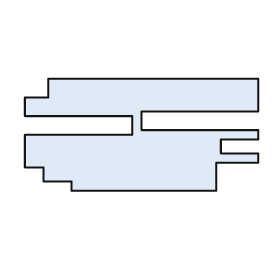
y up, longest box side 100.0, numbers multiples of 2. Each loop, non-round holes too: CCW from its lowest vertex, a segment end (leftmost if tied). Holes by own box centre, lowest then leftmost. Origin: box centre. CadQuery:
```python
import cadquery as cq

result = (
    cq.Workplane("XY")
    .moveTo(-30.0, -24.0)
    .lineTo(32.0, -24.0)
    .lineTo(32.0, -12.0)
    .lineTo(50.0, -12.0)
    .lineTo(50.0, -8.0)
    .lineTo(34.0, -8.0)
    .lineTo(34.0, -2.0)
    .lineTo(50.0, -2.0)
    .lineTo(50.0, 2.0)
    .lineTo(0.0, 2.0)
    .lineTo(0.0, 10.0)
    .lineTo(50.0, 10.0)
    .lineTo(50.0, 24.0)
    .lineTo(-40.0, 24.0)
    .lineTo(-40.0, 16.0)
    .lineTo(-50.0, 16.0)
    .lineTo(-50.0, 8.0)
    .lineTo(-4.0, 8.0)
    .lineTo(-4.0, 0.0)
    .lineTo(-50.0, 0.0)
    .lineTo(-50.0, -14.0)
    .lineTo(-42.0, -14.0)
    .lineTo(-42.0, -20.0)
    .lineTo(-30.0, -20.0)
    .close()
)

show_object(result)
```